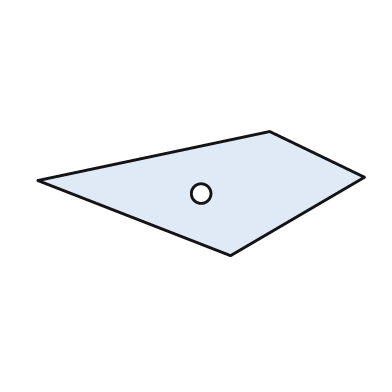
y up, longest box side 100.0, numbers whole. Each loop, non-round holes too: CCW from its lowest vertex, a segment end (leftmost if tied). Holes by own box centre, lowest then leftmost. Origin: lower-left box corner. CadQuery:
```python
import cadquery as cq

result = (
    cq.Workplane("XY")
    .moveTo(59.0, 0.0)
    .lineTo(100.0, 24.0)
    .lineTo(71.0, 38.0)
    .lineTo(0.0, 23.0)
    .close()
    .moveTo(50.0, 19.0)
    .circle(3.0)
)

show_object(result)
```